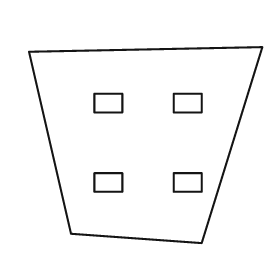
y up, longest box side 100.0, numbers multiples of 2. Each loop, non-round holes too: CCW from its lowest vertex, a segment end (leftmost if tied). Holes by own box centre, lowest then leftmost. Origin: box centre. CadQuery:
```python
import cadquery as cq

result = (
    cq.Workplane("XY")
    .moveTo(24.0, -42.0)
    .lineTo(50.0, 42.0)
    .lineTo(-50.0, 40.0)
    .lineTo(-32.0, -38.0)
    .close()
    .moveTo(-22.0, -20.0)
    .lineTo(-10.0, -20.0)
    .lineTo(-10.0, -12.0)
    .lineTo(-22.0, -12.0)
    .close()
    .moveTo(12.0, -20.0)
    .lineTo(24.0, -20.0)
    .lineTo(24.0, -12.0)
    .lineTo(12.0, -12.0)
    .close()
    .moveTo(-22.0, 14.0)
    .lineTo(-10.0, 14.0)
    .lineTo(-10.0, 22.0)
    .lineTo(-22.0, 22.0)
    .close()
    .moveTo(12.0, 14.0)
    .lineTo(24.0, 14.0)
    .lineTo(24.0, 22.0)
    .lineTo(12.0, 22.0)
    .close()
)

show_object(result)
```